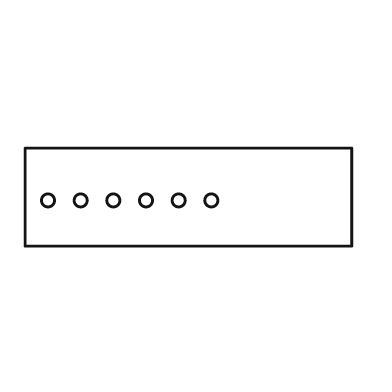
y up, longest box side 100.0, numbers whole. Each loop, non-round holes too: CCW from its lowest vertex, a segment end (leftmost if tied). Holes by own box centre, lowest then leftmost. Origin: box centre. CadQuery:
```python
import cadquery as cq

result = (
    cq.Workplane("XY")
    .moveTo(-50.0, -15.0)
    .lineTo(50.0, -15.0)
    .lineTo(50.0, 15.0)
    .lineTo(-50.0, 15.0)
    .close()
    .moveTo(-43.0, -1.0)
    .circle(2.0)
    .moveTo(-33.0, -1.0)
    .circle(2.0)
    .moveTo(-23.0, -1.0)
    .circle(2.0)
    .moveTo(-13.0, -1.0)
    .circle(2.0)
    .moveTo(-3.0, -1.0)
    .circle(2.0)
    .moveTo(7.0, -1.0)
    .circle(2.0)
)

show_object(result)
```